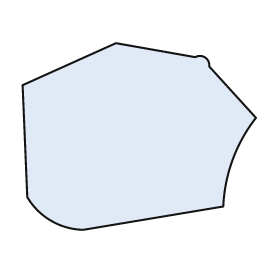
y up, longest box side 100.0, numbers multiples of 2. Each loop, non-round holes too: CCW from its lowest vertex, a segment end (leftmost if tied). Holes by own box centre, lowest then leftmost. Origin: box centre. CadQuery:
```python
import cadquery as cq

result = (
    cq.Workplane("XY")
    .moveTo(-24.0, -40.0)
    .lineTo(36.0, -30.0)
    .threePointArc((40.0, -10.0), (50.0, 8.0))
    .lineTo(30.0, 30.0)
    .threePointArc((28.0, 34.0), (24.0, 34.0))
    .lineTo(-10.0, 40.0)
    .lineTo(-50.0, 22.0)
    .lineTo(-48.0, -26.0)
    .threePointArc((-38.0, -36.0), (-24.0, -40.0))
    .close()
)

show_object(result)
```